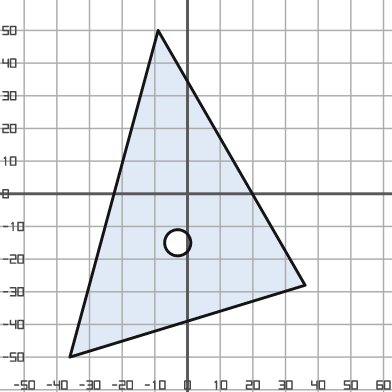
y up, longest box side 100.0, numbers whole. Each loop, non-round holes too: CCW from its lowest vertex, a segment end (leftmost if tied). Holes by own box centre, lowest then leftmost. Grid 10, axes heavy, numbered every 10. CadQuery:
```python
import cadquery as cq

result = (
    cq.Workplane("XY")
    .moveTo(-36.0, -50.0)
    .lineTo(36.0, -28.0)
    .lineTo(-9.0, 50.0)
    .close()
    .moveTo(-3.0, -15.0)
    .circle(4.0)
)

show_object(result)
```